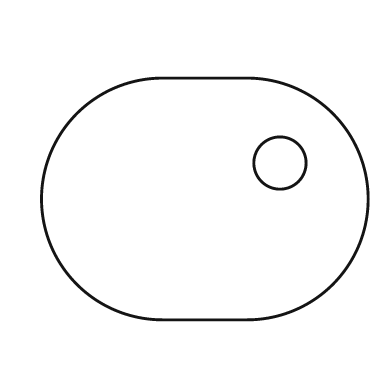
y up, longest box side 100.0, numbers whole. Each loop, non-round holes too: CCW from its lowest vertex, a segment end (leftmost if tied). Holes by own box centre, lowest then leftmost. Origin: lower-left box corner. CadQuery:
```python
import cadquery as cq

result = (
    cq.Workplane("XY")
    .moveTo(37.0, 0.0)
    .lineTo(63.0, 0.0)
    .threePointArc((100.0, 37.0), (63.0, 74.0))
    .lineTo(37.0, 74.0)
    .threePointArc((0.0, 37.0), (37.0, 0.0))
    .close()
    .moveTo(73.0, 48.0)
    .circle(8.0)
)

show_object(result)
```